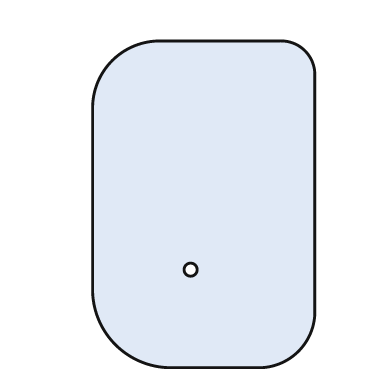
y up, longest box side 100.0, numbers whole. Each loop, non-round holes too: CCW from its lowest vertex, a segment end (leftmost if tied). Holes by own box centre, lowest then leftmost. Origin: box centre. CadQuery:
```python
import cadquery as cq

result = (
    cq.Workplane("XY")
    .moveTo(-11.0, -50.0)
    .lineTo(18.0, -50.0)
    .threePointArc((29.0, -45.0), (34.0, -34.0))
    .lineTo(34.0, 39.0)
    .threePointArc((31.0, 47.0), (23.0, 50.0))
    .lineTo(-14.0, 50.0)
    .threePointArc((-28.0, 44.0), (-34.0, 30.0))
    .lineTo(-34.0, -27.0)
    .threePointArc((-27.0, -43.0), (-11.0, -50.0))
    .close()
    .moveTo(-4.0, -20.0)
    .circle(2.0)
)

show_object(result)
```